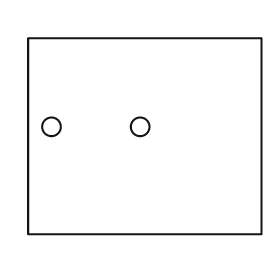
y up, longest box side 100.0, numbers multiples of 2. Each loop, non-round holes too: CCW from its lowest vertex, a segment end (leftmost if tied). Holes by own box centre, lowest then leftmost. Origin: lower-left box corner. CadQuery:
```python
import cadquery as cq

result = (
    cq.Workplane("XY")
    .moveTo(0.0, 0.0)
    .lineTo(100.0, 0.0)
    .lineTo(100.0, 84.0)
    .lineTo(0.0, 84.0)
    .close()
    .moveTo(10.0, 46.0)
    .circle(4.0)
    .moveTo(48.0, 46.0)
    .circle(4.0)
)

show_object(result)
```